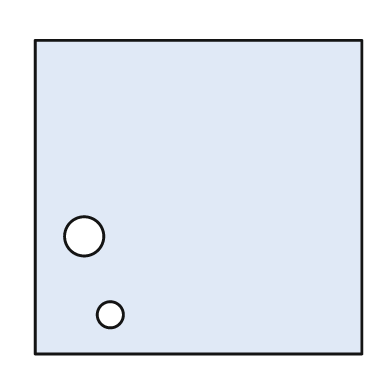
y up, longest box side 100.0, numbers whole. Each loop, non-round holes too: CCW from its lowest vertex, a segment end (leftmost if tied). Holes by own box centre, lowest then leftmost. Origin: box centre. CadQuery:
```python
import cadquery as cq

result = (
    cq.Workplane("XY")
    .moveTo(-50.0, -48.0)
    .lineTo(50.0, -48.0)
    .lineTo(50.0, 48.0)
    .lineTo(-50.0, 48.0)
    .close()
    .moveTo(-27.0, -36.0)
    .circle(4.0)
    .moveTo(-35.0, -12.0)
    .circle(6.0)
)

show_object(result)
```